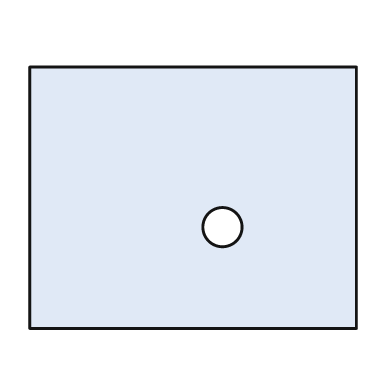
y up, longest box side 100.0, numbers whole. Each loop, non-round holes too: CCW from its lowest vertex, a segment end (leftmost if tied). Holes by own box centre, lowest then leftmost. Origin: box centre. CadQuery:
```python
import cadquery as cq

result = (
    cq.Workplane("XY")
    .moveTo(-50.0, -40.0)
    .lineTo(50.0, -40.0)
    .lineTo(50.0, 40.0)
    .lineTo(-50.0, 40.0)
    .close()
    .moveTo(9.0, -9.0)
    .circle(6.0)
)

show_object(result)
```